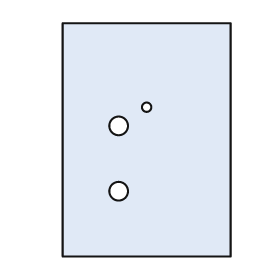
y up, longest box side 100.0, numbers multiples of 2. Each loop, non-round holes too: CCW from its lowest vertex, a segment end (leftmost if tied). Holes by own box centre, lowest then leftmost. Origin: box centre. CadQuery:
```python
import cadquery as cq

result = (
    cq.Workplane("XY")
    .moveTo(-36.0, -50.0)
    .lineTo(36.0, -50.0)
    .lineTo(36.0, 50.0)
    .lineTo(-36.0, 50.0)
    .close()
    .moveTo(-12.0, -22.0)
    .circle(4.0)
    .moveTo(-12.0, 6.0)
    .circle(4.0)
    .moveTo(0.0, 14.0)
    .circle(2.0)
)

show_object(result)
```